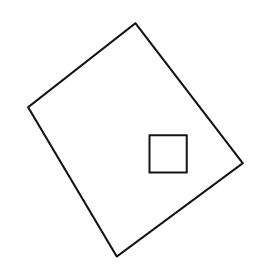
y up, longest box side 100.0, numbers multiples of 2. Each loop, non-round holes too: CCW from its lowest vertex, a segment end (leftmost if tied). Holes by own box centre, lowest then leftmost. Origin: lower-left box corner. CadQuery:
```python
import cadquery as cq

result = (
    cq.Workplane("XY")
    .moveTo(38.0, 0.0)
    .lineTo(92.0, 40.0)
    .lineTo(46.0, 100.0)
    .lineTo(0.0, 64.0)
    .close()
    .moveTo(52.0, 36.0)
    .lineTo(68.0, 36.0)
    .lineTo(68.0, 52.0)
    .lineTo(52.0, 52.0)
    .close()
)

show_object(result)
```